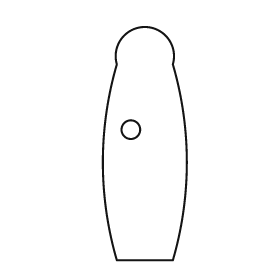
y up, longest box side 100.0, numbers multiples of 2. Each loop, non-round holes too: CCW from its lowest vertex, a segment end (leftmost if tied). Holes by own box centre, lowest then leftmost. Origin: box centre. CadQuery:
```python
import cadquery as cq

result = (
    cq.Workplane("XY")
    .moveTo(-12.0, -50.0)
    .lineTo(12.0, -50.0)
    .threePointArc((18.0, -8.0), (12.0, 34.0))
    .threePointArc((0.0, 50.0), (-12.0, 34.0))
    .threePointArc((-18.0, -8.0), (-12.0, -50.0))
    .close()
    .moveTo(-6.0, 6.0)
    .circle(4.0)
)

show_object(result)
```